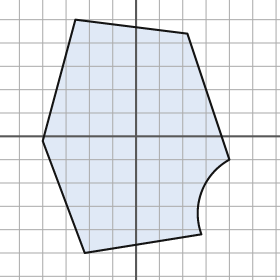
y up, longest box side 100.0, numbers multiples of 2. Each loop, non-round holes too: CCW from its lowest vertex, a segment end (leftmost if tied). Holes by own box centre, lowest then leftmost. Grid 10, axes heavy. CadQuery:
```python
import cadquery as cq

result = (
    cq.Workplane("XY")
    .moveTo(-22.0, -50.0)
    .lineTo(28.0, -42.0)
    .threePointArc((28.0, -24.0), (40.0, -10.0))
    .lineTo(22.0, 44.0)
    .lineTo(-26.0, 50.0)
    .lineTo(-40.0, -2.0)
    .close()
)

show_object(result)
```